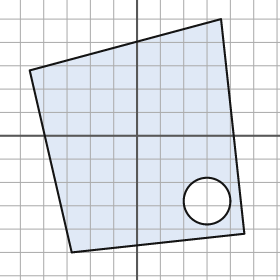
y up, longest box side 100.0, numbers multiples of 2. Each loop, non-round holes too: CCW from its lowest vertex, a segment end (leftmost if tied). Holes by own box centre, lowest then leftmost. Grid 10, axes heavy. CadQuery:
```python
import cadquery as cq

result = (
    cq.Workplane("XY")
    .moveTo(-28.0, -50.0)
    .lineTo(46.0, -42.0)
    .lineTo(36.0, 50.0)
    .lineTo(-46.0, 28.0)
    .close()
    .moveTo(30.0, -28.0)
    .circle(10.0)
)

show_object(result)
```